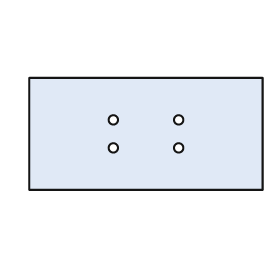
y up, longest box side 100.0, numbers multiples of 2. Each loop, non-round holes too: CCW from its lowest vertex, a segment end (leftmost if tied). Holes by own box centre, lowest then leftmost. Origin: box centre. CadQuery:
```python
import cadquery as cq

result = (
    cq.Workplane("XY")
    .moveTo(-50.0, -24.0)
    .lineTo(50.0, -24.0)
    .lineTo(50.0, 24.0)
    .lineTo(-50.0, 24.0)
    .close()
    .moveTo(-14.0, -6.0)
    .circle(2.0)
    .moveTo(14.0, -6.0)
    .circle(2.0)
    .moveTo(-14.0, 6.0)
    .circle(2.0)
    .moveTo(14.0, 6.0)
    .circle(2.0)
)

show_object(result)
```